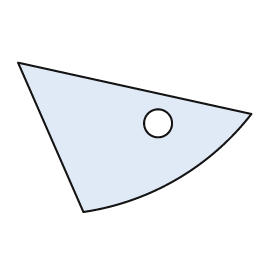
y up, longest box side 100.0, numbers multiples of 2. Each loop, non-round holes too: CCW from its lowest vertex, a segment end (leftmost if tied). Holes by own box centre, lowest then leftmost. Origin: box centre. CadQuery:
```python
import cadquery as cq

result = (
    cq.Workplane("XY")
    .moveTo(-22.0, -32.0)
    .threePointArc((18.0, -18.0), (50.0, 10.0))
    .lineTo(-50.0, 32.0)
    .close()
    .moveTo(10.0, 6.0)
    .circle(6.0)
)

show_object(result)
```